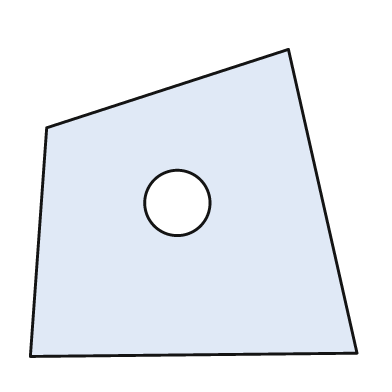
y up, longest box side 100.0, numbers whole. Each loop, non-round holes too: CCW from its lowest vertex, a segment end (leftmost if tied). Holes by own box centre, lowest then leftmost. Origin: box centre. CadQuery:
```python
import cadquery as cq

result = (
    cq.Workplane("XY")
    .moveTo(-50.0, -47.0)
    .lineTo(50.0, -46.0)
    .lineTo(29.0, 47.0)
    .lineTo(-45.0, 23.0)
    .close()
    .moveTo(-5.0, 0.0)
    .circle(10.0)
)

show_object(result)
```